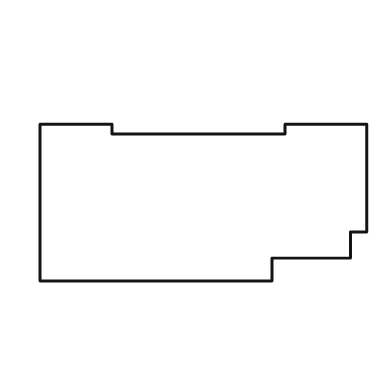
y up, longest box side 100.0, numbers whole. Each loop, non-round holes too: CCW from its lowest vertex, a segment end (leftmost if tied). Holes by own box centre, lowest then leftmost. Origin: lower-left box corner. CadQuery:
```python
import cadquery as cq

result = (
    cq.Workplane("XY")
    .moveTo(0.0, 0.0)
    .lineTo(71.0, 0.0)
    .lineTo(71.0, 7.0)
    .lineTo(95.0, 7.0)
    .lineTo(95.0, 15.0)
    .lineTo(100.0, 15.0)
    .lineTo(100.0, 48.0)
    .lineTo(75.0, 48.0)
    .lineTo(75.0, 45.0)
    .lineTo(22.0, 45.0)
    .lineTo(22.0, 48.0)
    .lineTo(0.0, 48.0)
    .close()
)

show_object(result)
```